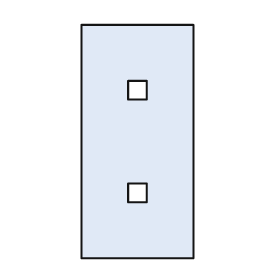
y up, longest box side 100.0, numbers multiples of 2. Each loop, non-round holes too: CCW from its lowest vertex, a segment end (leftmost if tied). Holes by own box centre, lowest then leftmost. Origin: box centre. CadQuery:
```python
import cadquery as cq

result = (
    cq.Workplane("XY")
    .moveTo(-24.0, -50.0)
    .lineTo(24.0, -50.0)
    .lineTo(24.0, 50.0)
    .lineTo(-24.0, 50.0)
    .close()
    .moveTo(-4.0, -26.0)
    .lineTo(4.0, -26.0)
    .lineTo(4.0, -18.0)
    .lineTo(-4.0, -18.0)
    .close()
    .moveTo(-4.0, 18.0)
    .lineTo(4.0, 18.0)
    .lineTo(4.0, 26.0)
    .lineTo(-4.0, 26.0)
    .close()
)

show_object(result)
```